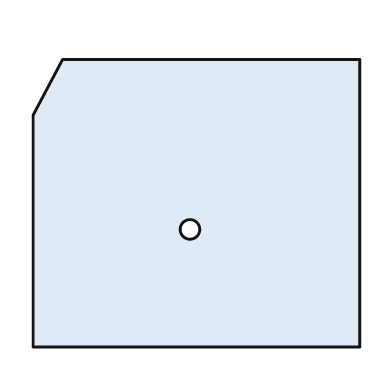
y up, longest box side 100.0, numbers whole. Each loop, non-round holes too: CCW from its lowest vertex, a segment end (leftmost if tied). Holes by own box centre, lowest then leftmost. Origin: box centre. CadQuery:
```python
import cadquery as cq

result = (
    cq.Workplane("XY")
    .moveTo(-50.0, -44.0)
    .lineTo(50.0, -44.0)
    .lineTo(50.0, 44.0)
    .lineTo(-41.0, 44.0)
    .lineTo(-50.0, 27.0)
    .close()
    .moveTo(-2.0, -8.0)
    .circle(3.0)
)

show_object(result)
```